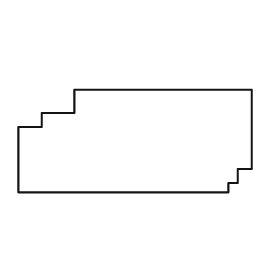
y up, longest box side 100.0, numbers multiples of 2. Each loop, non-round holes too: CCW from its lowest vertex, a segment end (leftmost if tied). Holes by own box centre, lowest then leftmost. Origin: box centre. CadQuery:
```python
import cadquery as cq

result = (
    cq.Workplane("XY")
    .moveTo(-50.0, -22.0)
    .lineTo(40.0, -22.0)
    .lineTo(40.0, -18.0)
    .lineTo(44.0, -18.0)
    .lineTo(44.0, -12.0)
    .lineTo(50.0, -12.0)
    .lineTo(50.0, 22.0)
    .lineTo(-26.0, 22.0)
    .lineTo(-26.0, 12.0)
    .lineTo(-40.0, 12.0)
    .lineTo(-40.0, 6.0)
    .lineTo(-50.0, 6.0)
    .close()
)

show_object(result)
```